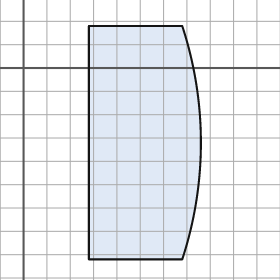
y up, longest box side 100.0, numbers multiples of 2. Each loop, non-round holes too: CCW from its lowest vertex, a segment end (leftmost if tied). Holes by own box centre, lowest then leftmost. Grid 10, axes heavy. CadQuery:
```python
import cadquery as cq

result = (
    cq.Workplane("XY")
    .moveTo(28.0, -82.0)
    .lineTo(68.0, -82.0)
    .threePointArc((76.0, -32.0), (68.0, 18.0))
    .lineTo(28.0, 18.0)
    .close()
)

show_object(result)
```